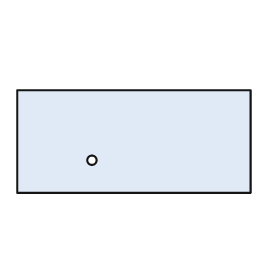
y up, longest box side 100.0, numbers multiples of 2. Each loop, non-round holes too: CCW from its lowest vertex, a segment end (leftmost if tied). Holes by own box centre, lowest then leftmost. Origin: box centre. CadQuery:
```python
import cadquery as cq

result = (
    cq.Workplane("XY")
    .moveTo(-50.0, -22.0)
    .lineTo(50.0, -22.0)
    .lineTo(50.0, 22.0)
    .lineTo(-50.0, 22.0)
    .close()
    .moveTo(-18.0, -8.0)
    .circle(2.0)
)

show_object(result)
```